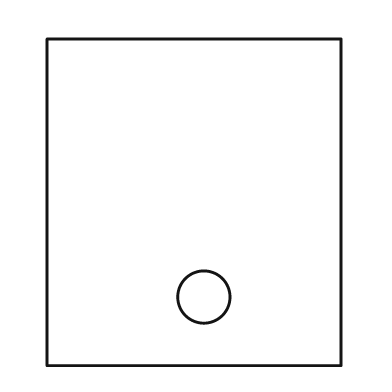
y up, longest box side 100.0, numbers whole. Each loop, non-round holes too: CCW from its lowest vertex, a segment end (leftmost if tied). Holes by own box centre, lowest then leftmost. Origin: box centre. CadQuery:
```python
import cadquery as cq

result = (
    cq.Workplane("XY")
    .moveTo(-45.0, -50.0)
    .lineTo(45.0, -50.0)
    .lineTo(45.0, 50.0)
    .lineTo(-45.0, 50.0)
    .close()
    .moveTo(3.0, -29.0)
    .circle(8.0)
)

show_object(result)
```